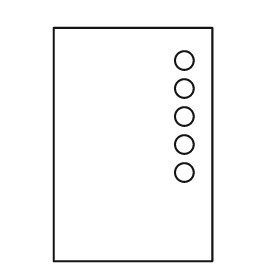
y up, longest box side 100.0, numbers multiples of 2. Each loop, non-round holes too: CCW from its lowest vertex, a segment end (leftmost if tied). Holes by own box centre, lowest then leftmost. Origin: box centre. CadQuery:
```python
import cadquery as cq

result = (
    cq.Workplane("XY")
    .moveTo(-34.0, -50.0)
    .lineTo(34.0, -50.0)
    .lineTo(34.0, 50.0)
    .lineTo(-34.0, 50.0)
    .close()
    .moveTo(22.0, -12.0)
    .circle(4.0)
    .moveTo(22.0, 0.0)
    .circle(4.0)
    .moveTo(22.0, 12.0)
    .circle(4.0)
    .moveTo(22.0, 24.0)
    .circle(4.0)
    .moveTo(22.0, 36.0)
    .circle(4.0)
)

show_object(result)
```